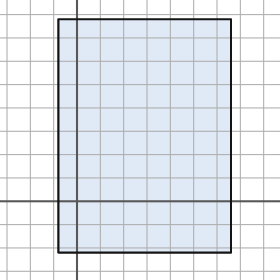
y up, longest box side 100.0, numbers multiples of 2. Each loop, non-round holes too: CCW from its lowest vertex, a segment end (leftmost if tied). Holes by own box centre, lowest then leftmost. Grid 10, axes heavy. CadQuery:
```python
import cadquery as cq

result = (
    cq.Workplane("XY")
    .moveTo(-8.0, -22.0)
    .lineTo(66.0, -22.0)
    .lineTo(66.0, 78.0)
    .lineTo(-8.0, 78.0)
    .close()
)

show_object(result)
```